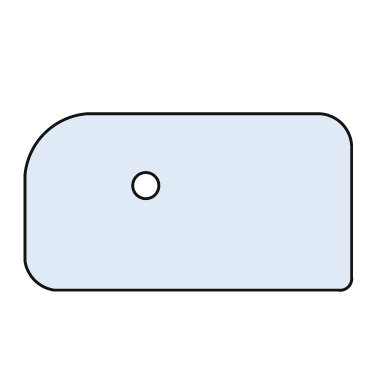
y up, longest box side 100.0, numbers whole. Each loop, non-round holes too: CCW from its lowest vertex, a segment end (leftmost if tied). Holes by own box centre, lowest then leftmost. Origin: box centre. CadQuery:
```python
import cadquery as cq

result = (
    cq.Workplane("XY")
    .moveTo(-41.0, -27.0)
    .lineTo(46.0, -27.0)
    .threePointArc((49.0, -26.0), (50.0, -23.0))
    .lineTo(50.0, 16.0)
    .threePointArc((47.0, 24.0), (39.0, 27.0))
    .lineTo(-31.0, 27.0)
    .threePointArc((-44.0, 21.0), (-50.0, 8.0))
    .lineTo(-50.0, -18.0)
    .threePointArc((-47.0, -24.0), (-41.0, -27.0))
    .close()
    .moveTo(-13.0, 5.0)
    .circle(4.0)
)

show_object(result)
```